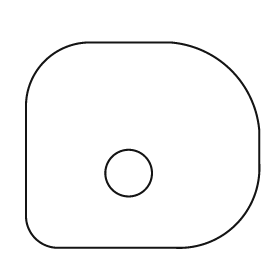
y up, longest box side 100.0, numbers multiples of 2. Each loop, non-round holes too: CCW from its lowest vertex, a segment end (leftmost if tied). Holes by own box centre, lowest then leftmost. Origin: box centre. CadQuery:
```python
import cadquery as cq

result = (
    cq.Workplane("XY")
    .moveTo(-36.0, -44.0)
    .lineTo(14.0, -44.0)
    .threePointArc((40.0, -34.0), (50.0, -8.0))
    .lineTo(50.0, 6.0)
    .threePointArc((38.0, 32.0), (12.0, 44.0))
    .lineTo(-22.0, 44.0)
    .threePointArc((-42.0, 36.0), (-50.0, 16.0))
    .lineTo(-50.0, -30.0)
    .threePointArc((-46.0, -40.0), (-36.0, -44.0))
    .close()
    .moveTo(-6.0, -12.0)
    .circle(10.0)
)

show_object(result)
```